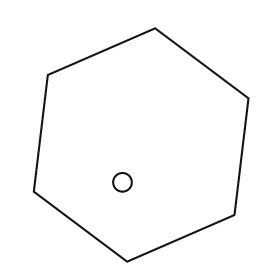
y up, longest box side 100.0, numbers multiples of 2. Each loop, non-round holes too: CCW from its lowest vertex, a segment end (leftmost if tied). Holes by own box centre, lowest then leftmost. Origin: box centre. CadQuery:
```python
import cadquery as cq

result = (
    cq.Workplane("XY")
    .moveTo(-6.0, -50.0)
    .lineTo(40.0, -30.0)
    .lineTo(46.0, 20.0)
    .lineTo(6.0, 50.0)
    .lineTo(-40.0, 30.0)
    .lineTo(-46.0, -20.0)
    .close()
    .moveTo(-8.0, -16.0)
    .circle(4.0)
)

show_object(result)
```